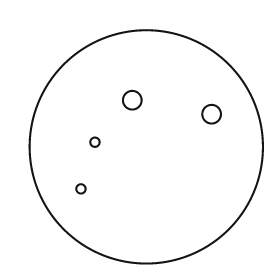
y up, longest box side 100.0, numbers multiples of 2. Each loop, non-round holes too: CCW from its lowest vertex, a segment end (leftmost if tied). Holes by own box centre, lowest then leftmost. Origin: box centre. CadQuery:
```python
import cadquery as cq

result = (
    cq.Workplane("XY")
    .moveTo(0.0, 0.0)
    .circle(50.0)
    .moveTo(-28.0, -18.0)
    .circle(2.0)
    .moveTo(-22.0, 2.0)
    .circle(2.0)
    .moveTo(28.0, 14.0)
    .circle(4.0)
    .moveTo(-6.0, 20.0)
    .circle(4.0)
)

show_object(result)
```